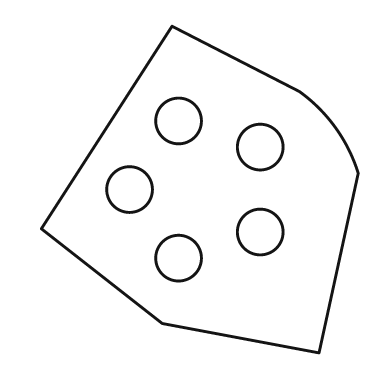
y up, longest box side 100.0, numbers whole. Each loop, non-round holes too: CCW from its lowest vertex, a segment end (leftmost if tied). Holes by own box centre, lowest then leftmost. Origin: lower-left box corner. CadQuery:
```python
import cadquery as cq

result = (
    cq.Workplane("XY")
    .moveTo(85.0, 0.0)
    .lineTo(97.0, 55.0)
    .threePointArc((90.0, 69.0), (79.0, 80.0))
    .lineTo(40.0, 100.0)
    .lineTo(0.0, 38.0)
    .lineTo(37.0, 9.0)
    .close()
    .moveTo(42.0, 29.0)
    .circle(7.0)
    .moveTo(67.0, 37.0)
    .circle(7.0)
    .moveTo(27.0, 50.0)
    .circle(7.0)
    .moveTo(67.0, 63.0)
    .circle(7.0)
    .moveTo(42.0, 71.0)
    .circle(7.0)
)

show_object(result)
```